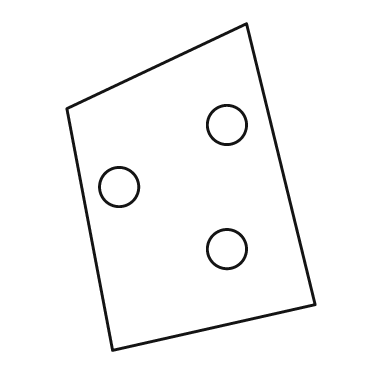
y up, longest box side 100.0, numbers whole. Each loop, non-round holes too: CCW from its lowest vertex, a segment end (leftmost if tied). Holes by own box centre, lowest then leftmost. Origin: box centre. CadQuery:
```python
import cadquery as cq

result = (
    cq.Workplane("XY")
    .moveTo(-24.0, -50.0)
    .lineTo(38.0, -36.0)
    .lineTo(17.0, 50.0)
    .lineTo(-38.0, 24.0)
    .close()
    .moveTo(11.0, -19.0)
    .circle(6.0)
    .moveTo(-22.0, 0.0)
    .circle(6.0)
    .moveTo(11.0, 19.0)
    .circle(6.0)
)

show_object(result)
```